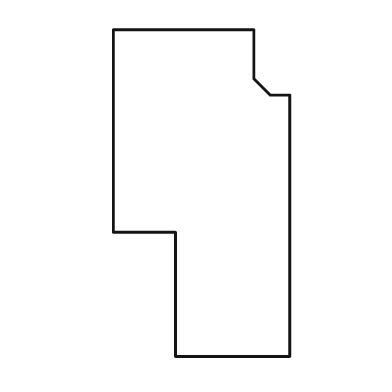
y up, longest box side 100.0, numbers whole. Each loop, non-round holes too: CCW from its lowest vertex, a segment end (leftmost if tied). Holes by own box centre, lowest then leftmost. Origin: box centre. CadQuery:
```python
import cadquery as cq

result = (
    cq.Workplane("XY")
    .moveTo(-8.0, -50.0)
    .lineTo(27.0, -50.0)
    .lineTo(27.0, 30.0)
    .lineTo(21.0, 30.0)
    .lineTo(16.0, 35.0)
    .lineTo(16.0, 50.0)
    .lineTo(-27.0, 50.0)
    .lineTo(-27.0, -12.0)
    .lineTo(-8.0, -12.0)
    .close()
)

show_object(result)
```